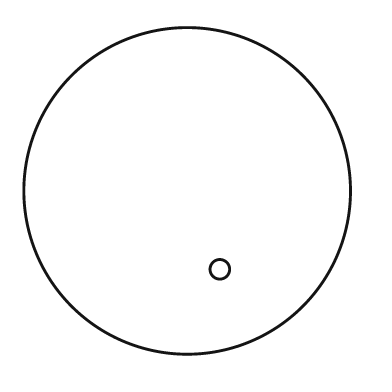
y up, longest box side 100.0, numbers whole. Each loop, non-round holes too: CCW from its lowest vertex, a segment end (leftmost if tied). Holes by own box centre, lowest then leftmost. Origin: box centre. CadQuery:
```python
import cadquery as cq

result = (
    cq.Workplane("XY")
    .moveTo(0.0, 0.0)
    .circle(50.0)
    .moveTo(10.0, -24.0)
    .circle(3.0)
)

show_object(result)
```